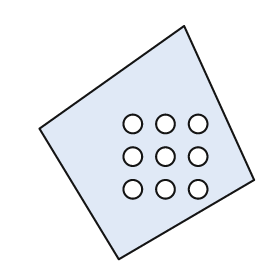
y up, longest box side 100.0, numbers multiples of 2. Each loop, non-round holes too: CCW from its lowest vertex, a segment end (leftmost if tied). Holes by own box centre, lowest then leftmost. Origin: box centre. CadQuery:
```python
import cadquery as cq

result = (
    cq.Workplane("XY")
    .moveTo(-12.0, -50.0)
    .lineTo(46.0, -16.0)
    .lineTo(16.0, 50.0)
    .lineTo(-46.0, 6.0)
    .close()
    .moveTo(-6.0, -20.0)
    .circle(4.0)
    .moveTo(8.0, -20.0)
    .circle(4.0)
    .moveTo(22.0, -20.0)
    .circle(4.0)
    .moveTo(-6.0, -6.0)
    .circle(4.0)
    .moveTo(8.0, -6.0)
    .circle(4.0)
    .moveTo(22.0, -6.0)
    .circle(4.0)
    .moveTo(-6.0, 8.0)
    .circle(4.0)
    .moveTo(8.0, 8.0)
    .circle(4.0)
    .moveTo(22.0, 8.0)
    .circle(4.0)
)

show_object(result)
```